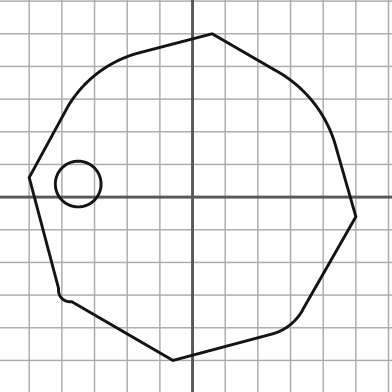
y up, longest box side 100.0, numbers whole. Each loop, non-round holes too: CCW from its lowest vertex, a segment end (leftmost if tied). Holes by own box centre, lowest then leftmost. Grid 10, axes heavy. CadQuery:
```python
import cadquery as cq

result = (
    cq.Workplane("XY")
    .moveTo(-6.0, -50.0)
    .lineTo(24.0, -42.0)
    .threePointArc((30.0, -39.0), (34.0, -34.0))
    .lineTo(50.0, -6.0)
    .lineTo(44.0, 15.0)
    .threePointArc((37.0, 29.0), (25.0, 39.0))
    .lineTo(6.0, 50.0)
    .lineTo(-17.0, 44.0)
    .threePointArc((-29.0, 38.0), (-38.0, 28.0))
    .lineTo(-50.0, 6.0)
    .lineTo(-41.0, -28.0)
    .threePointArc((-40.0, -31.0), (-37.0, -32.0))
    .close()
    .moveTo(-35.0, 4.0)
    .circle(7.0)
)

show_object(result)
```